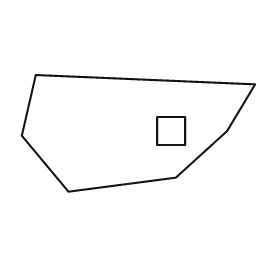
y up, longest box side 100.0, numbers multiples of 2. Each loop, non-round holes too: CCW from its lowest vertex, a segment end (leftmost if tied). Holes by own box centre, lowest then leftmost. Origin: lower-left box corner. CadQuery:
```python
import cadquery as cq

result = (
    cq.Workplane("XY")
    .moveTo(20.0, 0.0)
    .lineTo(66.0, 6.0)
    .lineTo(88.0, 26.0)
    .lineTo(100.0, 46.0)
    .lineTo(6.0, 50.0)
    .lineTo(0.0, 24.0)
    .close()
    .moveTo(58.0, 20.0)
    .lineTo(70.0, 20.0)
    .lineTo(70.0, 32.0)
    .lineTo(58.0, 32.0)
    .close()
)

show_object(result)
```